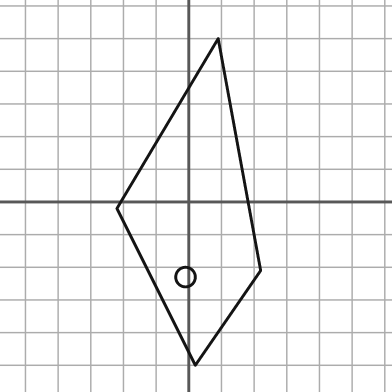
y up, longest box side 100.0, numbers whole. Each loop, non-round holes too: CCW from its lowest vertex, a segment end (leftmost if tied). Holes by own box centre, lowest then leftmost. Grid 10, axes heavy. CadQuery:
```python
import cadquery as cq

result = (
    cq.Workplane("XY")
    .moveTo(2.0, -50.0)
    .lineTo(22.0, -21.0)
    .lineTo(9.0, 50.0)
    .lineTo(-22.0, -2.0)
    .close()
    .moveTo(-1.0, -23.0)
    .circle(3.0)
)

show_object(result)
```